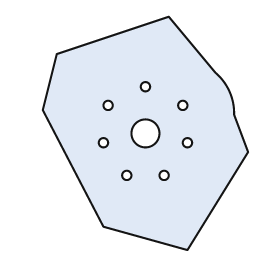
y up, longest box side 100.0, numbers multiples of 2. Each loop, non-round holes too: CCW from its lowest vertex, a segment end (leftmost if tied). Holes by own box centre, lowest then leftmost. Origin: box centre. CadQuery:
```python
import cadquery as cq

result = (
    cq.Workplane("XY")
    .moveTo(18.0, -50.0)
    .lineTo(44.0, -8.0)
    .lineTo(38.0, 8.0)
    .threePointArc((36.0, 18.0), (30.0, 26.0))
    .lineTo(10.0, 50.0)
    .lineTo(-38.0, 34.0)
    .lineTo(-44.0, 10.0)
    .lineTo(-18.0, -40.0)
    .close()
    .moveTo(-8.0, -18.0)
    .circle(2.0)
    .moveTo(8.0, -18.0)
    .circle(2.0)
    .moveTo(-18.0, -4.0)
    .circle(2.0)
    .moveTo(18.0, -4.0)
    .circle(2.0)
    .moveTo(0.0, 0.0)
    .circle(6.0)
    .moveTo(-16.0, 12.0)
    .circle(2.0)
    .moveTo(16.0, 12.0)
    .circle(2.0)
    .moveTo(0.0, 20.0)
    .circle(2.0)
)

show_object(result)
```